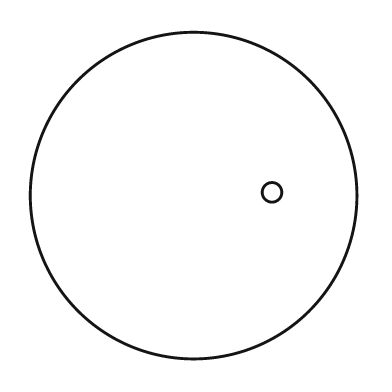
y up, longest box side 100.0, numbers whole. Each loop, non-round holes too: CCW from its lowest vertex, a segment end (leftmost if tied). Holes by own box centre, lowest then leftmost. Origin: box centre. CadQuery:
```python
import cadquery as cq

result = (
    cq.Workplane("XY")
    .moveTo(0.0, 0.0)
    .circle(50.0)
    .moveTo(24.0, 1.0)
    .circle(3.0)
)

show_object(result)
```